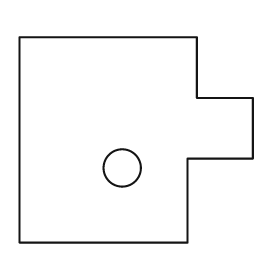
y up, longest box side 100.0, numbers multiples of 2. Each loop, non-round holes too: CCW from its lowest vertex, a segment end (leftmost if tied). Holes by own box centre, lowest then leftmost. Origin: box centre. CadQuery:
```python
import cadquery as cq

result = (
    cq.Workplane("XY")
    .moveTo(-50.0, -44.0)
    .lineTo(22.0, -44.0)
    .lineTo(22.0, -8.0)
    .lineTo(50.0, -8.0)
    .lineTo(50.0, 18.0)
    .lineTo(26.0, 18.0)
    .lineTo(26.0, 44.0)
    .lineTo(-50.0, 44.0)
    .close()
    .moveTo(-6.0, -12.0)
    .circle(8.0)
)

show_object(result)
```